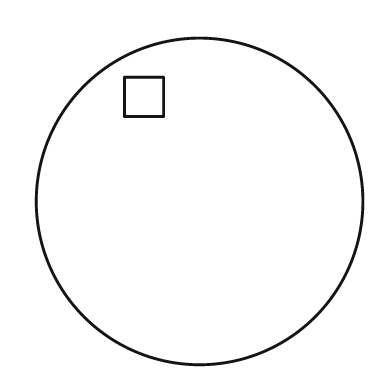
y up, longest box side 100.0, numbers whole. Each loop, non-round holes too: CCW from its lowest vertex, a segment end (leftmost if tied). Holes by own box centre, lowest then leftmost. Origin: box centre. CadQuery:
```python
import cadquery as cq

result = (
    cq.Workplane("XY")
    .moveTo(0.0, 0.0)
    .circle(50.0)
    .moveTo(-23.0, 26.0)
    .lineTo(-11.0, 26.0)
    .lineTo(-11.0, 38.0)
    .lineTo(-23.0, 38.0)
    .close()
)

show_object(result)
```